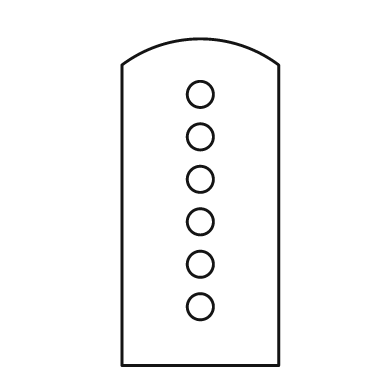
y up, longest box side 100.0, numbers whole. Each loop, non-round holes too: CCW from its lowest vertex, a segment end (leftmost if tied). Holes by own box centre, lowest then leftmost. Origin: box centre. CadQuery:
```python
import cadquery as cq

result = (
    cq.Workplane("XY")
    .moveTo(-24.0, -50.0)
    .lineTo(24.0, -50.0)
    .lineTo(24.0, 42.0)
    .threePointArc((0.0, 50.0), (-24.0, 42.0))
    .close()
    .moveTo(0.0, -32.0)
    .circle(4.0)
    .moveTo(0.0, -19.0)
    .circle(4.0)
    .moveTo(0.0, -6.0)
    .circle(4.0)
    .moveTo(0.0, 7.0)
    .circle(4.0)
    .moveTo(0.0, 20.0)
    .circle(4.0)
    .moveTo(0.0, 33.0)
    .circle(4.0)
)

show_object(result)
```